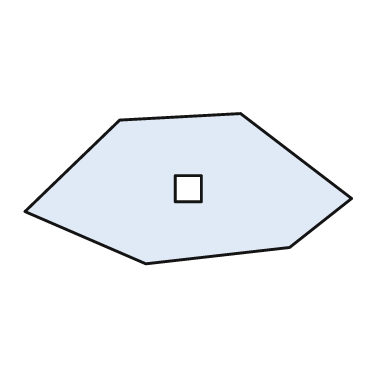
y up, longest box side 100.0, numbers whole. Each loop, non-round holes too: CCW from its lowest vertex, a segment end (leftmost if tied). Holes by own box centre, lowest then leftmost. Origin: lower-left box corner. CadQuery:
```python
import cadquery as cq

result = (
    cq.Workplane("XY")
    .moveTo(37.0, 0.0)
    .lineTo(81.0, 5.0)
    .lineTo(100.0, 20.0)
    .lineTo(66.0, 46.0)
    .lineTo(29.0, 44.0)
    .lineTo(0.0, 16.0)
    .close()
    .moveTo(46.0, 19.0)
    .lineTo(54.0, 19.0)
    .lineTo(54.0, 27.0)
    .lineTo(46.0, 27.0)
    .close()
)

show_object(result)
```